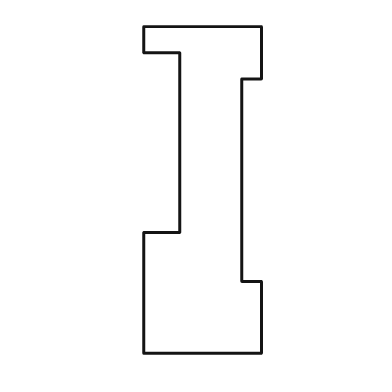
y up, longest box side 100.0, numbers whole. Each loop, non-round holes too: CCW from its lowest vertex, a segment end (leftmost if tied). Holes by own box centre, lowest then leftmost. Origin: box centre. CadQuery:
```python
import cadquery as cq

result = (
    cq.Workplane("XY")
    .moveTo(-18.0, -50.0)
    .lineTo(18.0, -50.0)
    .lineTo(18.0, -28.0)
    .lineTo(12.0, -28.0)
    .lineTo(12.0, 34.0)
    .lineTo(18.0, 34.0)
    .lineTo(18.0, 50.0)
    .lineTo(-18.0, 50.0)
    .lineTo(-18.0, 42.0)
    .lineTo(-7.0, 42.0)
    .lineTo(-7.0, -13.0)
    .lineTo(-18.0, -13.0)
    .close()
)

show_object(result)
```